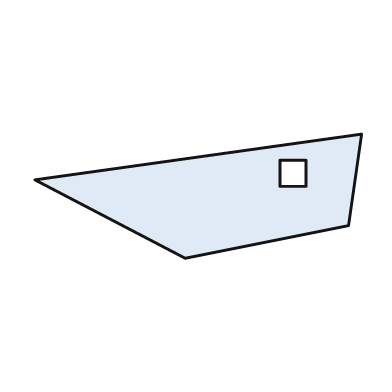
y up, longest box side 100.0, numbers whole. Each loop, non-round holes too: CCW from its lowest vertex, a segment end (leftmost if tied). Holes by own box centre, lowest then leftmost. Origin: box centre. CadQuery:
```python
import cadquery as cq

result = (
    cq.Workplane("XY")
    .moveTo(-4.0, -19.0)
    .lineTo(46.0, -9.0)
    .lineTo(50.0, 19.0)
    .lineTo(-50.0, 5.0)
    .close()
    .moveTo(25.0, 3.0)
    .lineTo(33.0, 3.0)
    .lineTo(33.0, 11.0)
    .lineTo(25.0, 11.0)
    .close()
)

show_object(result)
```